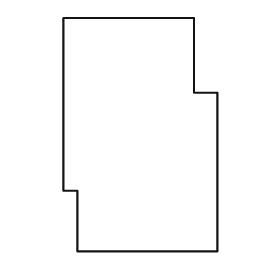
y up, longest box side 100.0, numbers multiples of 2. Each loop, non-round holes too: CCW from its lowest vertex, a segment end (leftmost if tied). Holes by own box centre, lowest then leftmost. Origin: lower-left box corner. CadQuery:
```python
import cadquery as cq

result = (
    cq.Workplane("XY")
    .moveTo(6.0, 0.0)
    .lineTo(66.0, 0.0)
    .lineTo(66.0, 68.0)
    .lineTo(56.0, 68.0)
    .lineTo(56.0, 100.0)
    .lineTo(0.0, 100.0)
    .lineTo(0.0, 26.0)
    .lineTo(6.0, 26.0)
    .close()
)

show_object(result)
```